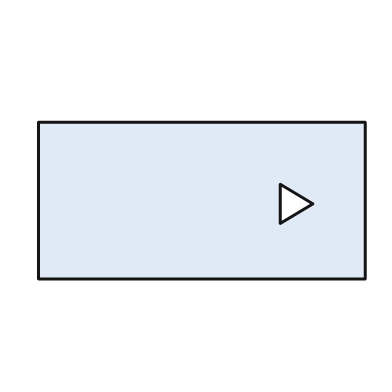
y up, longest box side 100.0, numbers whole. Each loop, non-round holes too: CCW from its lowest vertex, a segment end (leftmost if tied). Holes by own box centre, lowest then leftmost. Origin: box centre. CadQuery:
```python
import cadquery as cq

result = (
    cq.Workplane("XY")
    .moveTo(-50.0, -24.0)
    .lineTo(50.0, -24.0)
    .lineTo(50.0, 24.0)
    .lineTo(-50.0, 24.0)
    .close()
    .moveTo(24.0, -7.0)
    .lineTo(34.0, -1.0)
    .lineTo(24.0, 5.0)
    .close()
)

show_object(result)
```